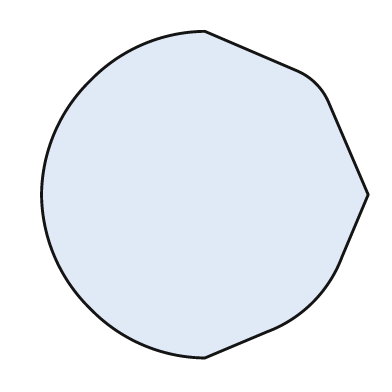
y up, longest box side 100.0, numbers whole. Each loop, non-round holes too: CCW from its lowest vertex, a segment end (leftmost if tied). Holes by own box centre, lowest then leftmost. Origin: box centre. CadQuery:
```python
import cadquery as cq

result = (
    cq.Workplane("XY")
    .moveTo(0.0, -50.0)
    .lineTo(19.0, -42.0)
    .threePointArc((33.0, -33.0), (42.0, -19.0))
    .lineTo(50.0, 0.0)
    .lineTo(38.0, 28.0)
    .threePointArc((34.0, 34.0), (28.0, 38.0))
    .lineTo(0.0, 50.0)
    .threePointArc((-19.0, 46.0), (-35.0, 35.0))
    .threePointArc((-46.0, 19.0), (-50.0, 0.0))
    .threePointArc((-46.0, -19.0), (-35.0, -35.0))
    .threePointArc((-19.0, -46.0), (0.0, -50.0))
    .close()
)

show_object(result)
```